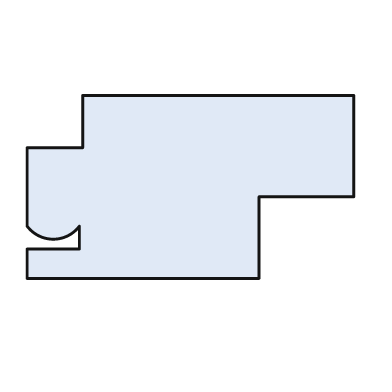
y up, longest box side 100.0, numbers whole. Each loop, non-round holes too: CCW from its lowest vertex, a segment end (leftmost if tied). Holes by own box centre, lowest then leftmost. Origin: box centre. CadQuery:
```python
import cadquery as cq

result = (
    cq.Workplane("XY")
    .moveTo(-50.0, -28.0)
    .lineTo(21.0, -28.0)
    .lineTo(21.0, -3.0)
    .lineTo(50.0, -3.0)
    .lineTo(50.0, 28.0)
    .lineTo(-33.0, 28.0)
    .lineTo(-33.0, 12.0)
    .lineTo(-50.0, 12.0)
    .lineTo(-50.0, -12.0)
    .threePointArc((-42.0, -16.0), (-34.0, -12.0))
    .lineTo(-34.0, -19.0)
    .lineTo(-50.0, -19.0)
    .close()
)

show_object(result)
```